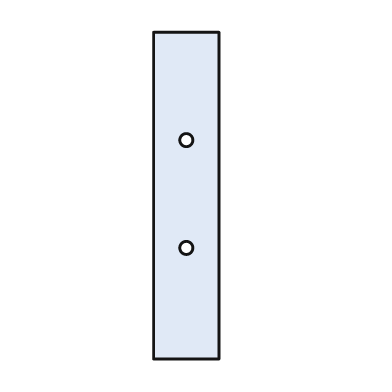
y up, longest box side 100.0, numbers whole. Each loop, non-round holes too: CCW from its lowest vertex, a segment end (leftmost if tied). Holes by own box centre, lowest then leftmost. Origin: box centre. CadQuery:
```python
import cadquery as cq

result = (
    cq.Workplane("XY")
    .moveTo(-10.0, -50.0)
    .lineTo(10.0, -50.0)
    .lineTo(10.0, 50.0)
    .lineTo(-10.0, 50.0)
    .close()
    .moveTo(0.0, -16.0)
    .circle(2.0)
    .moveTo(0.0, 17.0)
    .circle(2.0)
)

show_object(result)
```